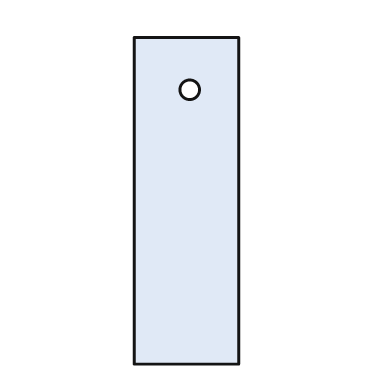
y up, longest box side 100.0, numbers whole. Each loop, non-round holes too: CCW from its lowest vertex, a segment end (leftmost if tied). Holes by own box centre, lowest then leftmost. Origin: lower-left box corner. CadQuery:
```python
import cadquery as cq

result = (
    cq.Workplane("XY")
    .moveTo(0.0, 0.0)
    .lineTo(32.0, 0.0)
    .lineTo(32.0, 100.0)
    .lineTo(0.0, 100.0)
    .close()
    .moveTo(17.0, 84.0)
    .circle(3.0)
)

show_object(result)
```